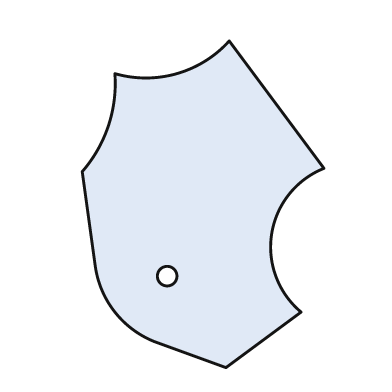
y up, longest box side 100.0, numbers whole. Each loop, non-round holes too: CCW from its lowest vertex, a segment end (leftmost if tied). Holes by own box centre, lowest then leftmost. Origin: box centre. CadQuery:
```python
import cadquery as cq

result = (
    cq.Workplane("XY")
    .moveTo(7.0, -50.0)
    .lineTo(30.0, -33.0)
    .threePointArc((21.0, -9.0), (37.0, 11.0))
    .lineTo(8.0, 50.0)
    .threePointArc((-8.0, 40.0), (-27.0, 40.0))
    .threePointArc((-29.0, 24.0), (-37.0, 10.0))
    .lineTo(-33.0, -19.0)
    .threePointArc((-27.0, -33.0), (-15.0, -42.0))
    .close()
    .moveTo(-11.0, -22.0)
    .circle(3.0)
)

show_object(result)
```